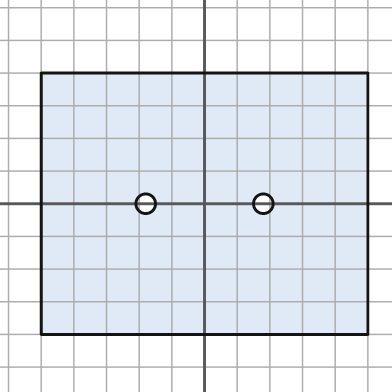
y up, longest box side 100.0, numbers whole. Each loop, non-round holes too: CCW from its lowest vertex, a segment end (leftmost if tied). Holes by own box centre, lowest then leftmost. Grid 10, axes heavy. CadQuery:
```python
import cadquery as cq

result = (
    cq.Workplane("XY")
    .moveTo(-50.0, -40.0)
    .lineTo(50.0, -40.0)
    .lineTo(50.0, 40.0)
    .lineTo(-50.0, 40.0)
    .close()
    .moveTo(-18.0, 0.0)
    .circle(3.0)
    .moveTo(18.0, 0.0)
    .circle(3.0)
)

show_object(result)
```